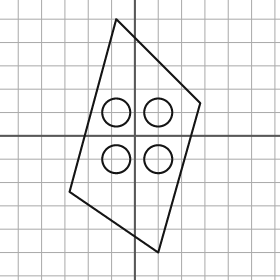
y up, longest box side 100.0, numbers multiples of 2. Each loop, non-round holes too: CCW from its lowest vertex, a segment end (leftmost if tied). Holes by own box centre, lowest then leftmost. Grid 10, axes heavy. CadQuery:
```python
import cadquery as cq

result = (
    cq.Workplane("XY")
    .moveTo(10.0, -50.0)
    .lineTo(28.0, 14.0)
    .lineTo(-8.0, 50.0)
    .lineTo(-28.0, -24.0)
    .close()
    .moveTo(-8.0, -10.0)
    .circle(6.0)
    .moveTo(10.0, -10.0)
    .circle(6.0)
    .moveTo(-8.0, 10.0)
    .circle(6.0)
    .moveTo(10.0, 10.0)
    .circle(6.0)
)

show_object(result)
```